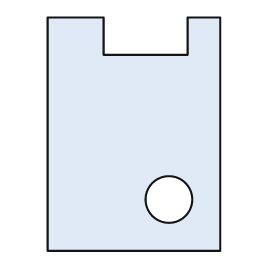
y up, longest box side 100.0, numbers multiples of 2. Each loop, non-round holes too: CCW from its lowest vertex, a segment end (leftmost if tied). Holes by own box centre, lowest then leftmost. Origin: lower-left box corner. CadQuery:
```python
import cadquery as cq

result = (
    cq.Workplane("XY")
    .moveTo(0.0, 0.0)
    .lineTo(74.0, 0.0)
    .lineTo(74.0, 100.0)
    .lineTo(60.0, 100.0)
    .lineTo(60.0, 84.0)
    .lineTo(24.0, 84.0)
    .lineTo(24.0, 100.0)
    .lineTo(0.0, 100.0)
    .close()
    .moveTo(52.0, 22.0)
    .circle(10.0)
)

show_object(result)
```